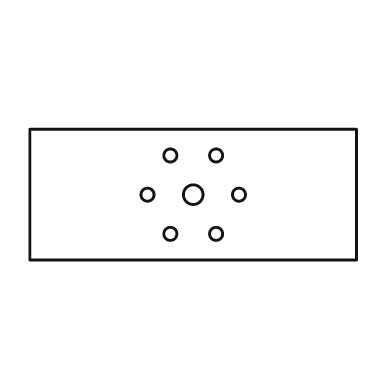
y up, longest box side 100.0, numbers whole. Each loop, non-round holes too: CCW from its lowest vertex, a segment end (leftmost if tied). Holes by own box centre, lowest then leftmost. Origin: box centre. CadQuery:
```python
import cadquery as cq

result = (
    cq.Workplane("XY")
    .moveTo(-50.0, -20.0)
    .lineTo(50.0, -20.0)
    .lineTo(50.0, 20.0)
    .lineTo(-50.0, 20.0)
    .close()
    .moveTo(-7.0, -12.0)
    .circle(2.0)
    .moveTo(7.0, -12.0)
    .circle(2.0)
    .moveTo(-14.0, 0.0)
    .circle(2.0)
    .moveTo(0.0, 0.0)
    .circle(3.0)
    .moveTo(14.0, 0.0)
    .circle(2.0)
    .moveTo(-7.0, 12.0)
    .circle(2.0)
    .moveTo(7.0, 12.0)
    .circle(2.0)
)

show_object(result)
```